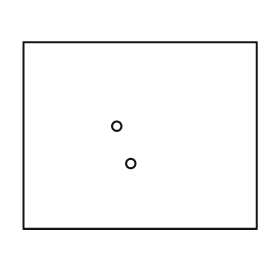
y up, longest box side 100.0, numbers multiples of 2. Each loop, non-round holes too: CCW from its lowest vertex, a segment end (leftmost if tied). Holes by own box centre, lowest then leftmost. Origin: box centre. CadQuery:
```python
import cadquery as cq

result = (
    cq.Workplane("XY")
    .moveTo(-50.0, -40.0)
    .lineTo(50.0, -40.0)
    .lineTo(50.0, 40.0)
    .lineTo(-50.0, 40.0)
    .close()
    .moveTo(-4.0, -12.0)
    .circle(2.0)
    .moveTo(-10.0, 4.0)
    .circle(2.0)
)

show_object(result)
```